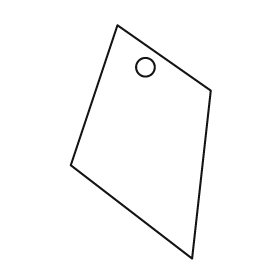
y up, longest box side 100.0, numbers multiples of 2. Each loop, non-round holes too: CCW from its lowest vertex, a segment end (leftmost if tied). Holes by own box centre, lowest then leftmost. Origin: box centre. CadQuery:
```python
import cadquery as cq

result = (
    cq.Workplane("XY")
    .moveTo(22.0, -50.0)
    .lineTo(30.0, 22.0)
    .lineTo(-10.0, 50.0)
    .lineTo(-30.0, -10.0)
    .close()
    .moveTo(2.0, 32.0)
    .circle(4.0)
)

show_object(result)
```